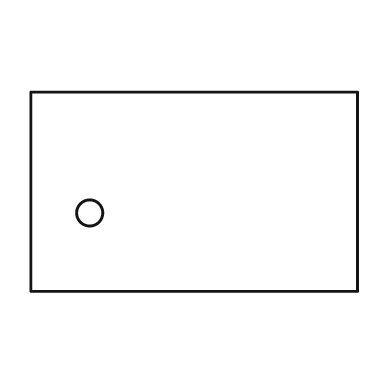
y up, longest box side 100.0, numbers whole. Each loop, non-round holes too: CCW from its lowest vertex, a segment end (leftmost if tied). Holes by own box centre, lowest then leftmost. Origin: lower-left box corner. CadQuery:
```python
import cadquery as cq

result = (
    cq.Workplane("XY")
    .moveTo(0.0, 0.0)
    .lineTo(100.0, 0.0)
    .lineTo(100.0, 61.0)
    .lineTo(0.0, 61.0)
    .close()
    .moveTo(18.0, 24.0)
    .circle(4.0)
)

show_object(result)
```